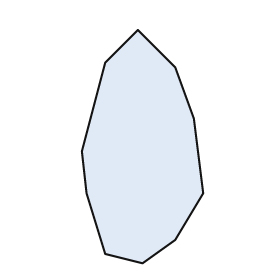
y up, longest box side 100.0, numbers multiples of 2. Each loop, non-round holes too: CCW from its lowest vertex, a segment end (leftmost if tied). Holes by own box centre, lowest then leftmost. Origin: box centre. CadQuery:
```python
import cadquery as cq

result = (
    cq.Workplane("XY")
    .moveTo(0.0, -50.0)
    .lineTo(14.0, -40.0)
    .lineTo(26.0, -20.0)
    .lineTo(22.0, 12.0)
    .lineTo(14.0, 34.0)
    .lineTo(-2.0, 50.0)
    .lineTo(-16.0, 36.0)
    .lineTo(-26.0, -2.0)
    .lineTo(-24.0, -20.0)
    .lineTo(-16.0, -46.0)
    .close()
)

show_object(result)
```